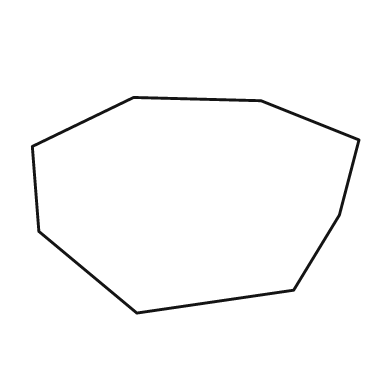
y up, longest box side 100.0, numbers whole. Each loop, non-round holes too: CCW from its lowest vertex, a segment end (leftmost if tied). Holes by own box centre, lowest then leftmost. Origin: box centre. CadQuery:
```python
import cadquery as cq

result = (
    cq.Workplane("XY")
    .moveTo(-18.0, -33.0)
    .lineTo(30.0, -26.0)
    .lineTo(44.0, -3.0)
    .lineTo(50.0, 20.0)
    .lineTo(20.0, 32.0)
    .lineTo(-19.0, 33.0)
    .lineTo(-50.0, 18.0)
    .lineTo(-48.0, -8.0)
    .close()
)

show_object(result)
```